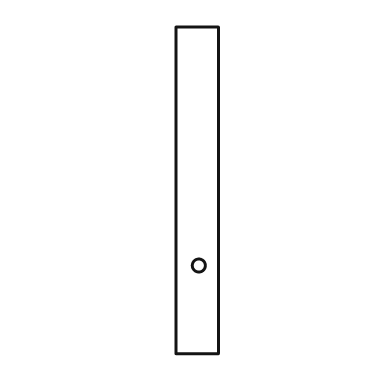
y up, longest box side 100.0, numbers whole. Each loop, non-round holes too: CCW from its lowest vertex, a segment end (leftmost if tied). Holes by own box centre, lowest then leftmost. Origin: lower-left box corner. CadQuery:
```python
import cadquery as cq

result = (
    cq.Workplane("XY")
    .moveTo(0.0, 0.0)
    .lineTo(13.0, 0.0)
    .lineTo(13.0, 100.0)
    .lineTo(0.0, 100.0)
    .close()
    .moveTo(7.0, 27.0)
    .circle(2.0)
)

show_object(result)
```